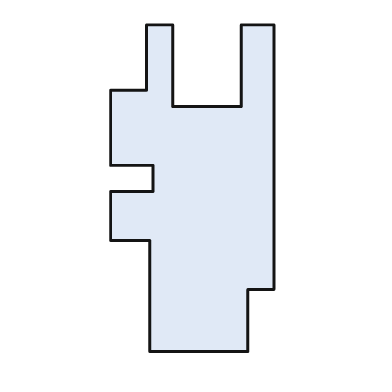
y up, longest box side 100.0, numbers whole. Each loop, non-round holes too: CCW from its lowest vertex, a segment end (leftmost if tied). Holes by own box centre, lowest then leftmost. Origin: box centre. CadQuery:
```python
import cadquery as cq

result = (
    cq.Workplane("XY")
    .moveTo(-13.0, -50.0)
    .lineTo(17.0, -50.0)
    .lineTo(17.0, -31.0)
    .lineTo(25.0, -31.0)
    .lineTo(25.0, 50.0)
    .lineTo(15.0, 50.0)
    .lineTo(15.0, 25.0)
    .lineTo(-6.0, 25.0)
    .lineTo(-6.0, 50.0)
    .lineTo(-14.0, 50.0)
    .lineTo(-14.0, 30.0)
    .lineTo(-25.0, 30.0)
    .lineTo(-25.0, 7.0)
    .lineTo(-12.0, 7.0)
    .lineTo(-12.0, -1.0)
    .lineTo(-25.0, -1.0)
    .lineTo(-25.0, -16.0)
    .lineTo(-13.0, -16.0)
    .close()
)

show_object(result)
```